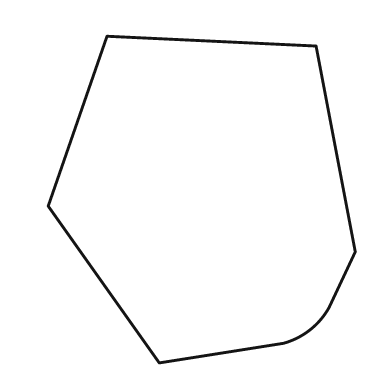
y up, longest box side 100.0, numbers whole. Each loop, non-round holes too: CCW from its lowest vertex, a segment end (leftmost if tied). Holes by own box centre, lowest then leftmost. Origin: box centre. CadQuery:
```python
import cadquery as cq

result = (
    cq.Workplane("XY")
    .moveTo(-13.0, -50.0)
    .lineTo(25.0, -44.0)
    .threePointArc((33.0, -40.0), (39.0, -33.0))
    .lineTo(47.0, -16.0)
    .lineTo(35.0, 47.0)
    .lineTo(-29.0, 50.0)
    .lineTo(-47.0, -2.0)
    .close()
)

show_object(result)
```